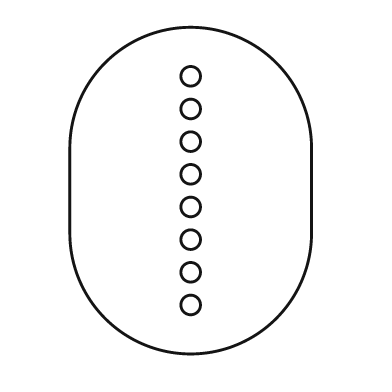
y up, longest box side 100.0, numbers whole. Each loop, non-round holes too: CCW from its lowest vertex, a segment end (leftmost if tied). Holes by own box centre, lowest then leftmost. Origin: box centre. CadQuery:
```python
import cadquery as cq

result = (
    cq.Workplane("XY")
    .moveTo(-37.0, -13.0)
    .threePointArc((0.0, -50.0), (37.0, -13.0))
    .lineTo(37.0, 13.0)
    .threePointArc((0.0, 50.0), (-37.0, 13.0))
    .close()
    .moveTo(0.0, -35.0)
    .circle(3.0)
    .moveTo(0.0, -25.0)
    .circle(3.0)
    .moveTo(0.0, -15.0)
    .circle(3.0)
    .moveTo(0.0, -5.0)
    .circle(3.0)
    .moveTo(0.0, 5.0)
    .circle(3.0)
    .moveTo(0.0, 15.0)
    .circle(3.0)
    .moveTo(0.0, 25.0)
    .circle(3.0)
    .moveTo(0.0, 35.0)
    .circle(3.0)
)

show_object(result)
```